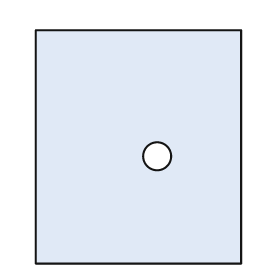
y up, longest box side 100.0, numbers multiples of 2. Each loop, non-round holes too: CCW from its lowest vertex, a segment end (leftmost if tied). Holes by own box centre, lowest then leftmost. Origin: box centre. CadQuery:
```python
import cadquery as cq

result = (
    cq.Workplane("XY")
    .moveTo(-44.0, -50.0)
    .lineTo(44.0, -50.0)
    .lineTo(44.0, 50.0)
    .lineTo(-44.0, 50.0)
    .close()
    .moveTo(8.0, -4.0)
    .circle(6.0)
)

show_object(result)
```